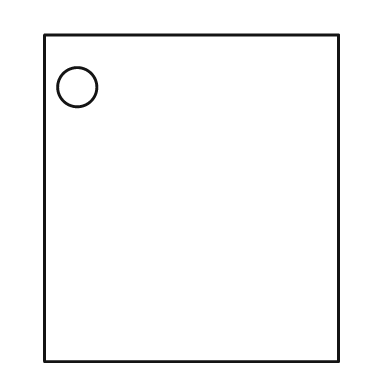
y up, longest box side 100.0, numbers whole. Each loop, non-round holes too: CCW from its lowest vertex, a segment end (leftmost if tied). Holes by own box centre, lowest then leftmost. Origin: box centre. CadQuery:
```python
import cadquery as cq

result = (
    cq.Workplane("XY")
    .moveTo(-45.0, -50.0)
    .lineTo(45.0, -50.0)
    .lineTo(45.0, 50.0)
    .lineTo(-45.0, 50.0)
    .close()
    .moveTo(-35.0, 34.0)
    .circle(6.0)
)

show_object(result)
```